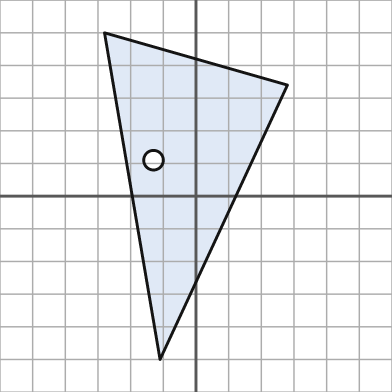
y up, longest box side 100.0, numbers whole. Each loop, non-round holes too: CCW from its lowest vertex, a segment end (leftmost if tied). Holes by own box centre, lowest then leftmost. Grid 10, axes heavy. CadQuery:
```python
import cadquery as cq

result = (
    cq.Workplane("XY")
    .moveTo(-11.0, -50.0)
    .lineTo(28.0, 34.0)
    .lineTo(-28.0, 50.0)
    .close()
    .moveTo(-13.0, 11.0)
    .circle(3.0)
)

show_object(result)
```